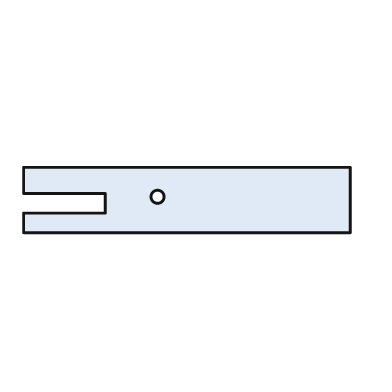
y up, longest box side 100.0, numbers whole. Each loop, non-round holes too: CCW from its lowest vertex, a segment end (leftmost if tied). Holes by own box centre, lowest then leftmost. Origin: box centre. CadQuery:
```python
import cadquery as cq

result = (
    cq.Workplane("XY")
    .moveTo(-50.0, -10.0)
    .lineTo(50.0, -10.0)
    .lineTo(50.0, 10.0)
    .lineTo(-50.0, 10.0)
    .lineTo(-50.0, 2.0)
    .lineTo(-25.0, 2.0)
    .lineTo(-25.0, -4.0)
    .lineTo(-50.0, -4.0)
    .close()
    .moveTo(-9.0, 1.0)
    .circle(2.0)
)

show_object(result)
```